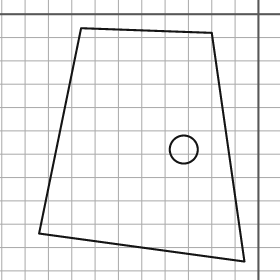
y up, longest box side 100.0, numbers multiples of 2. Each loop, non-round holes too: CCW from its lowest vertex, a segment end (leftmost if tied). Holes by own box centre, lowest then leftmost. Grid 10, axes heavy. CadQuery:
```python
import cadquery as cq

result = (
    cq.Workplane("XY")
    .moveTo(-6.0, -106.0)
    .lineTo(-20.0, -8.0)
    .lineTo(-76.0, -6.0)
    .lineTo(-94.0, -94.0)
    .close()
    .moveTo(-32.0, -58.0)
    .circle(6.0)
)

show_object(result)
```